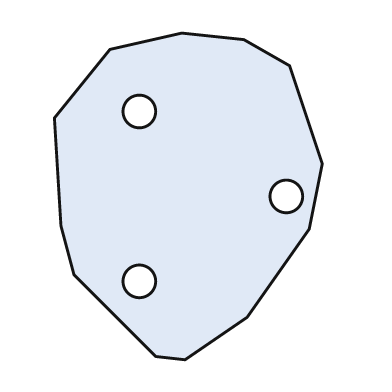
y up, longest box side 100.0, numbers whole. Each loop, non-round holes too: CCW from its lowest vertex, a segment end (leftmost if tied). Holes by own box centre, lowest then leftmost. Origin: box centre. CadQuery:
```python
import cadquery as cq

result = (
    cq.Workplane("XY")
    .moveTo(-1.0, -50.0)
    .lineTo(18.0, -37.0)
    .lineTo(37.0, -10.0)
    .lineTo(41.0, 10.0)
    .lineTo(31.0, 40.0)
    .lineTo(17.0, 48.0)
    .lineTo(-2.0, 50.0)
    .lineTo(-24.0, 45.0)
    .lineTo(-41.0, 24.0)
    .lineTo(-39.0, -9.0)
    .lineTo(-35.0, -24.0)
    .lineTo(-10.0, -49.0)
    .close()
    .moveTo(-15.0, -26.0)
    .circle(5.0)
    .moveTo(30.0, 0.0)
    .circle(5.0)
    .moveTo(-15.0, 26.0)
    .circle(5.0)
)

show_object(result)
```